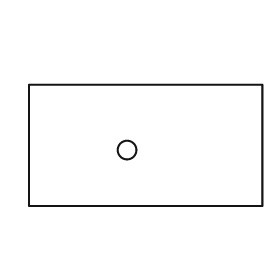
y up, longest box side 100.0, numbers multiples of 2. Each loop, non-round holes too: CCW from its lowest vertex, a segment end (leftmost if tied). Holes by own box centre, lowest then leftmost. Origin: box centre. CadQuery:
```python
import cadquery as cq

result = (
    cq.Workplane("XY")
    .moveTo(-50.0, -26.0)
    .lineTo(50.0, -26.0)
    .lineTo(50.0, 26.0)
    .lineTo(-50.0, 26.0)
    .close()
    .moveTo(-8.0, -2.0)
    .circle(4.0)
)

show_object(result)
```